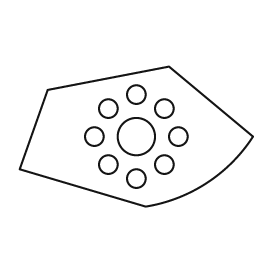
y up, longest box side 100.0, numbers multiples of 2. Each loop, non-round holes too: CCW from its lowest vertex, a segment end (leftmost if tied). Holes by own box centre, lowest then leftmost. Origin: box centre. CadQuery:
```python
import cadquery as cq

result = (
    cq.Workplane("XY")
    .moveTo(4.0, -30.0)
    .threePointArc((30.0, -20.0), (50.0, 0.0))
    .lineTo(14.0, 30.0)
    .lineTo(-38.0, 20.0)
    .lineTo(-50.0, -14.0)
    .close()
    .moveTo(0.0, -18.0)
    .circle(4.0)
    .moveTo(-12.0, -12.0)
    .circle(4.0)
    .moveTo(12.0, -12.0)
    .circle(4.0)
    .moveTo(-18.0, 0.0)
    .circle(4.0)
    .moveTo(0.0, 0.0)
    .circle(8.0)
    .moveTo(18.0, 0.0)
    .circle(4.0)
    .moveTo(-12.0, 12.0)
    .circle(4.0)
    .moveTo(12.0, 12.0)
    .circle(4.0)
    .moveTo(0.0, 18.0)
    .circle(4.0)
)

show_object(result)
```